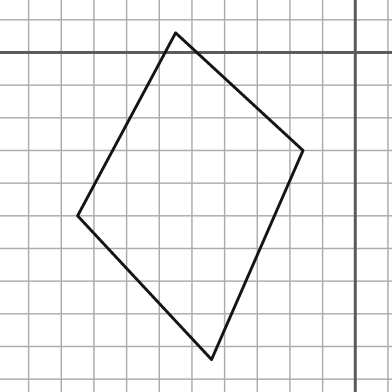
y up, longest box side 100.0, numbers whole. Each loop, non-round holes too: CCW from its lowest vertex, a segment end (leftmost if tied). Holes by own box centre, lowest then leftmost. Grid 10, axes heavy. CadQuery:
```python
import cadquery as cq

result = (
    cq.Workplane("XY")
    .moveTo(-44.0, -94.0)
    .lineTo(-16.0, -30.0)
    .lineTo(-55.0, 6.0)
    .lineTo(-85.0, -50.0)
    .close()
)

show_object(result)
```